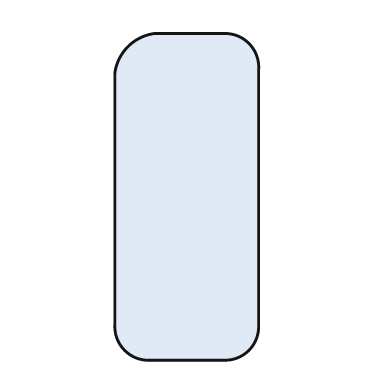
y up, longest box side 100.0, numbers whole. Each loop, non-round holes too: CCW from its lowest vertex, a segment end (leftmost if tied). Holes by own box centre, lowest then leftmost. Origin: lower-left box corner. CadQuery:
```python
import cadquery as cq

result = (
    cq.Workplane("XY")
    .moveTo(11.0, 0.0)
    .lineTo(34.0, 0.0)
    .threePointArc((41.0, 3.0), (44.0, 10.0))
    .lineTo(44.0, 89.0)
    .threePointArc((41.0, 97.0), (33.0, 100.0))
    .lineTo(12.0, 100.0)
    .threePointArc((4.0, 96.0), (0.0, 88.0))
    .lineTo(0.0, 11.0)
    .threePointArc((3.0, 3.0), (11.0, 0.0))
    .close()
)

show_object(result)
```